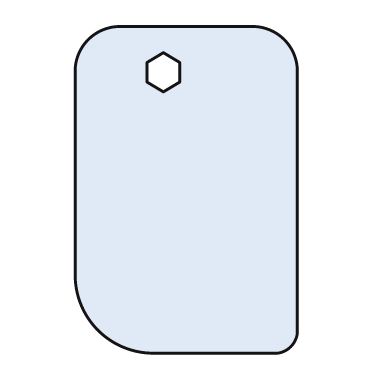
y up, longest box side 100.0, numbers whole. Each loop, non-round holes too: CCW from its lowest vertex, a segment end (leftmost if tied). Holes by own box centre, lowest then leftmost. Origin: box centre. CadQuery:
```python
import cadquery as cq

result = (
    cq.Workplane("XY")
    .moveTo(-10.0, -50.0)
    .lineTo(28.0, -50.0)
    .threePointArc((32.0, -48.0), (34.0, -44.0))
    .lineTo(34.0, 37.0)
    .threePointArc((30.0, 46.0), (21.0, 50.0))
    .lineTo(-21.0, 50.0)
    .threePointArc((-30.0, 46.0), (-34.0, 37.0))
    .lineTo(-34.0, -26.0)
    .threePointArc((-27.0, -43.0), (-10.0, -50.0))
    .close()
    .moveTo(-7.0, 30.0)
    .lineTo(-2.0, 33.0)
    .lineTo(-2.0, 39.0)
    .lineTo(-7.0, 42.0)
    .lineTo(-12.0, 39.0)
    .lineTo(-12.0, 33.0)
    .close()
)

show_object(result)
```